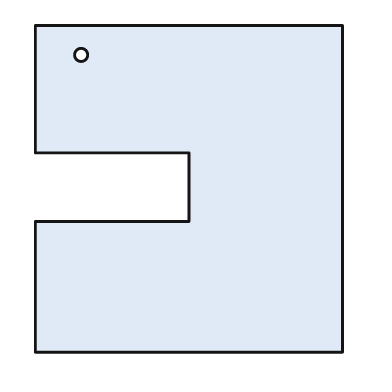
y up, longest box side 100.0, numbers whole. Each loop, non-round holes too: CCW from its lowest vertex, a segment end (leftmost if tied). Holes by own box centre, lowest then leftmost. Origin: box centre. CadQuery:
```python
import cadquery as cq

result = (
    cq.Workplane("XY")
    .moveTo(-47.0, -50.0)
    .lineTo(47.0, -50.0)
    .lineTo(47.0, 50.0)
    .lineTo(-47.0, 50.0)
    .lineTo(-47.0, 11.0)
    .lineTo(0.0, 11.0)
    .lineTo(0.0, -10.0)
    .lineTo(-47.0, -10.0)
    .close()
    .moveTo(-33.0, 41.0)
    .circle(2.0)
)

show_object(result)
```